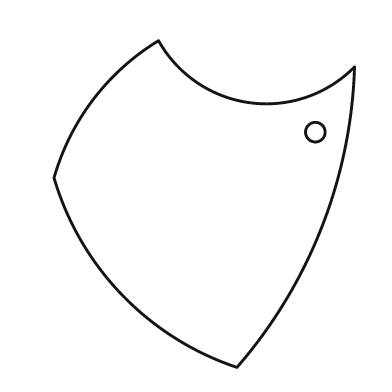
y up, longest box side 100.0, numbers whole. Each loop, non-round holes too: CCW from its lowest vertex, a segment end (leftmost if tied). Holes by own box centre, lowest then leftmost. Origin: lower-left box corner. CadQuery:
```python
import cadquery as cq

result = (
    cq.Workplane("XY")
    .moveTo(56.0, 0.0)
    .threePointArc((82.0, 43.0), (92.0, 92.0))
    .threePointArc((60.0, 81.0), (32.0, 100.0))
    .threePointArc((12.0, 82.0), (0.0, 58.0))
    .threePointArc((21.0, 22.0), (56.0, 0.0))
    .close()
    .moveTo(80.0, 72.0)
    .circle(3.0)
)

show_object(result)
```